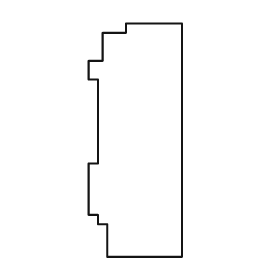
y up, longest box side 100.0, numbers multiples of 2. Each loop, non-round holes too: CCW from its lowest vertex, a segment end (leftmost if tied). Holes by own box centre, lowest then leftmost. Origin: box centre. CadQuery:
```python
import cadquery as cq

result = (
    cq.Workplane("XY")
    .moveTo(-12.0, -50.0)
    .lineTo(20.0, -50.0)
    .lineTo(20.0, 50.0)
    .lineTo(-4.0, 50.0)
    .lineTo(-4.0, 46.0)
    .lineTo(-14.0, 46.0)
    .lineTo(-14.0, 34.0)
    .lineTo(-20.0, 34.0)
    .lineTo(-20.0, 26.0)
    .lineTo(-16.0, 26.0)
    .lineTo(-16.0, -10.0)
    .lineTo(-20.0, -10.0)
    .lineTo(-20.0, -32.0)
    .lineTo(-16.0, -32.0)
    .lineTo(-16.0, -36.0)
    .lineTo(-12.0, -36.0)
    .close()
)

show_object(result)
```